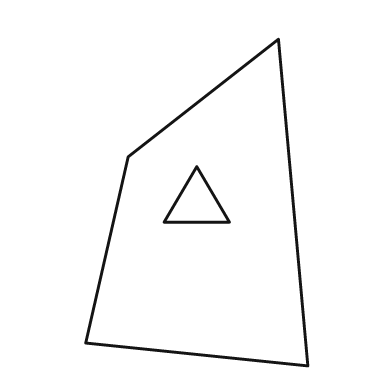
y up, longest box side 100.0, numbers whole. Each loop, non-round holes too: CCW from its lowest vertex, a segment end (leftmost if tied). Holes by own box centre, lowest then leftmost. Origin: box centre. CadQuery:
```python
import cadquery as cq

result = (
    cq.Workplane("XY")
    .moveTo(34.0, -50.0)
    .lineTo(25.0, 50.0)
    .lineTo(-21.0, 14.0)
    .lineTo(-34.0, -43.0)
    .close()
    .moveTo(-10.0, -6.0)
    .lineTo(10.0, -6.0)
    .lineTo(0.0, 11.0)
    .close()
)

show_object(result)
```